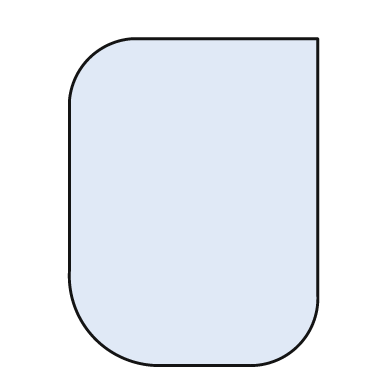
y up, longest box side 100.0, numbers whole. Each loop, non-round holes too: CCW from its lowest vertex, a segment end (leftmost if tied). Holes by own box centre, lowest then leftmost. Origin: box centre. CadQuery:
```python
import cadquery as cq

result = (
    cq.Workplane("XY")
    .moveTo(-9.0, -50.0)
    .lineTo(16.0, -50.0)
    .threePointArc((32.0, -44.0), (38.0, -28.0))
    .lineTo(38.0, 50.0)
    .lineTo(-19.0, 50.0)
    .threePointArc((-32.0, 44.0), (-38.0, 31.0))
    .lineTo(-38.0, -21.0)
    .threePointArc((-30.0, -42.0), (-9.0, -50.0))
    .close()
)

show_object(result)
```